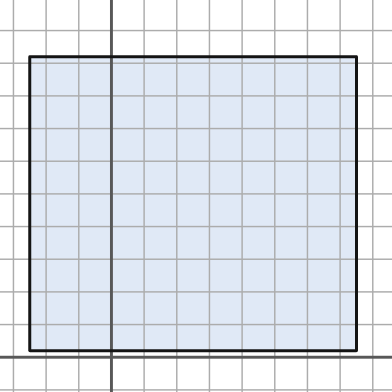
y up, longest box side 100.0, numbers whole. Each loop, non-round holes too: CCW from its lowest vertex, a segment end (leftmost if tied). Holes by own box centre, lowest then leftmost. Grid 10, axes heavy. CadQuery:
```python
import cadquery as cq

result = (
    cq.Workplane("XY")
    .moveTo(-25.0, 2.0)
    .lineTo(75.0, 2.0)
    .lineTo(75.0, 92.0)
    .lineTo(-25.0, 92.0)
    .close()
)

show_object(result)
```